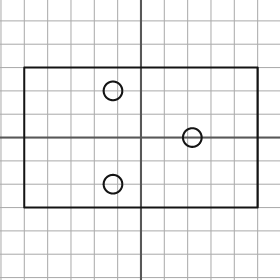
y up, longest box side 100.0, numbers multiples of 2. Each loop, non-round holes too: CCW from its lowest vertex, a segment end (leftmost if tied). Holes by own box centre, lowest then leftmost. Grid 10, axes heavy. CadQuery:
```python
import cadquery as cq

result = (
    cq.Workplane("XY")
    .moveTo(-50.0, -30.0)
    .lineTo(50.0, -30.0)
    .lineTo(50.0, 30.0)
    .lineTo(-50.0, 30.0)
    .close()
    .moveTo(-12.0, -20.0)
    .circle(4.0)
    .moveTo(22.0, 0.0)
    .circle(4.0)
    .moveTo(-12.0, 20.0)
    .circle(4.0)
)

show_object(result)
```